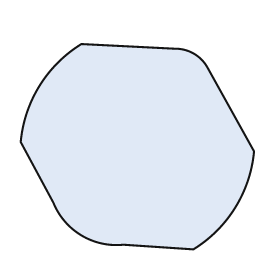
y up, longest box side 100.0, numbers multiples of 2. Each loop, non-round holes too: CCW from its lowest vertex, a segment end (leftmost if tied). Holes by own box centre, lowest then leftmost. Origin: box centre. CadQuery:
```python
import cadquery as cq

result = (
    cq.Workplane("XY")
    .moveTo(24.0, -44.0)
    .threePointArc((42.0, -26.0), (50.0, -2.0))
    .lineTo(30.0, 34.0)
    .threePointArc((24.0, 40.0), (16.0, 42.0))
    .lineTo(-24.0, 44.0)
    .threePointArc((-42.0, 26.0), (-50.0, 2.0))
    .lineTo(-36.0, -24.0)
    .threePointArc((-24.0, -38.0), (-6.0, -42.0))
    .close()
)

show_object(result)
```